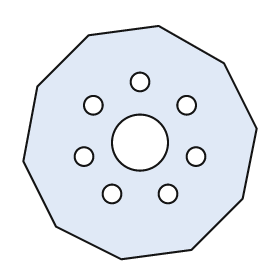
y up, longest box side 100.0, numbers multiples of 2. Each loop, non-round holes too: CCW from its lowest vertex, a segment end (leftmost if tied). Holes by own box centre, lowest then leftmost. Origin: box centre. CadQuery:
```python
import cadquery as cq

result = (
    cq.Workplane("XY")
    .moveTo(-8.0, -50.0)
    .lineTo(22.0, -46.0)
    .lineTo(44.0, -24.0)
    .lineTo(50.0, 6.0)
    .lineTo(36.0, 34.0)
    .lineTo(8.0, 50.0)
    .lineTo(-22.0, 46.0)
    .lineTo(-44.0, 24.0)
    .lineTo(-50.0, -8.0)
    .lineTo(-36.0, -36.0)
    .close()
    .moveTo(-12.0, -22.0)
    .circle(4.0)
    .moveTo(12.0, -22.0)
    .circle(4.0)
    .moveTo(-24.0, -6.0)
    .circle(4.0)
    .moveTo(24.0, -6.0)
    .circle(4.0)
    .moveTo(0.0, 0.0)
    .circle(12.0)
    .moveTo(-20.0, 16.0)
    .circle(4.0)
    .moveTo(20.0, 16.0)
    .circle(4.0)
    .moveTo(0.0, 26.0)
    .circle(4.0)
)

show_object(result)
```